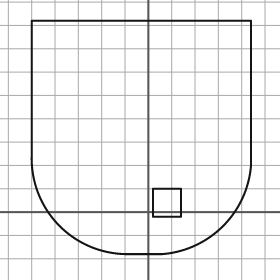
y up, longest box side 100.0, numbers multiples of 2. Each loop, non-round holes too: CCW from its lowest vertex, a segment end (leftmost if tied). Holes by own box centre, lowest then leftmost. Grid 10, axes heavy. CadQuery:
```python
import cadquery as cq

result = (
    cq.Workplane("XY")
    .moveTo(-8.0, -18.0)
    .lineTo(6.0, -18.0)
    .threePointArc((32.0, -6.0), (44.0, 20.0))
    .lineTo(44.0, 82.0)
    .lineTo(-50.0, 82.0)
    .lineTo(-50.0, 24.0)
    .threePointArc((-38.0, -6.0), (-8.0, -18.0))
    .close()
    .moveTo(2.0, -2.0)
    .lineTo(14.0, -2.0)
    .lineTo(14.0, 10.0)
    .lineTo(2.0, 10.0)
    .close()
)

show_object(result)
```